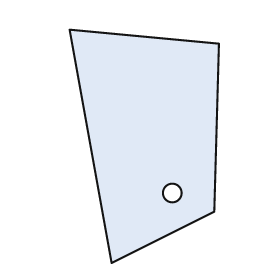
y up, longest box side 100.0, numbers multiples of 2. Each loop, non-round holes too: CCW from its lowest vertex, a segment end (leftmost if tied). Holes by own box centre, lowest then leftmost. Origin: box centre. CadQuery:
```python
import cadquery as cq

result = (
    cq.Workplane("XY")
    .moveTo(-14.0, -50.0)
    .lineTo(30.0, -28.0)
    .lineTo(32.0, 44.0)
    .lineTo(-32.0, 50.0)
    .close()
    .moveTo(12.0, -20.0)
    .circle(4.0)
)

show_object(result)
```